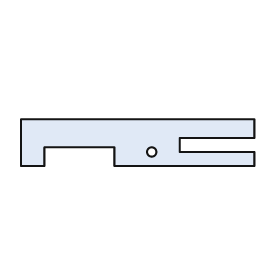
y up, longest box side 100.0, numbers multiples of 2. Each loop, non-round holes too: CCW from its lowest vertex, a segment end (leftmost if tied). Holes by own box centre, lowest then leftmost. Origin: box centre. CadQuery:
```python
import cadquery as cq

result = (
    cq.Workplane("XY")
    .moveTo(-50.0, -10.0)
    .lineTo(-40.0, -10.0)
    .lineTo(-40.0, -2.0)
    .lineTo(-10.0, -2.0)
    .lineTo(-10.0, -10.0)
    .lineTo(50.0, -10.0)
    .lineTo(50.0, -4.0)
    .lineTo(18.0, -4.0)
    .lineTo(18.0, 2.0)
    .lineTo(50.0, 2.0)
    .lineTo(50.0, 10.0)
    .lineTo(-50.0, 10.0)
    .close()
    .moveTo(6.0, -4.0)
    .circle(2.0)
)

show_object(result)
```